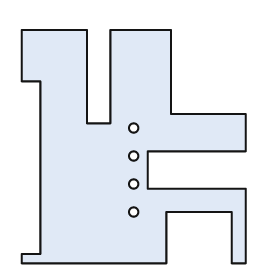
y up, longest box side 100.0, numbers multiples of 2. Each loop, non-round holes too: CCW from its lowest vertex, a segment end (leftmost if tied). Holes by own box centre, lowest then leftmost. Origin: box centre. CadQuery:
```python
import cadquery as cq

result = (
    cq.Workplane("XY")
    .moveTo(-48.0, -50.0)
    .lineTo(14.0, -50.0)
    .lineTo(14.0, -28.0)
    .lineTo(42.0, -28.0)
    .lineTo(42.0, -50.0)
    .lineTo(48.0, -50.0)
    .lineTo(48.0, -18.0)
    .lineTo(6.0, -18.0)
    .lineTo(6.0, -2.0)
    .lineTo(48.0, -2.0)
    .lineTo(48.0, 14.0)
    .lineTo(16.0, 14.0)
    .lineTo(16.0, 50.0)
    .lineTo(-10.0, 50.0)
    .lineTo(-10.0, 10.0)
    .lineTo(-20.0, 10.0)
    .lineTo(-20.0, 50.0)
    .lineTo(-48.0, 50.0)
    .lineTo(-48.0, 28.0)
    .lineTo(-40.0, 28.0)
    .lineTo(-40.0, -46.0)
    .lineTo(-48.0, -46.0)
    .close()
    .moveTo(0.0, -28.0)
    .circle(2.0)
    .moveTo(0.0, -16.0)
    .circle(2.0)
    .moveTo(0.0, -4.0)
    .circle(2.0)
    .moveTo(0.0, 8.0)
    .circle(2.0)
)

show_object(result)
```